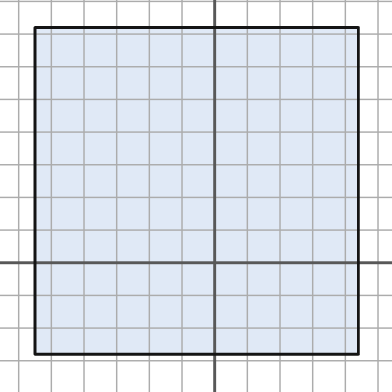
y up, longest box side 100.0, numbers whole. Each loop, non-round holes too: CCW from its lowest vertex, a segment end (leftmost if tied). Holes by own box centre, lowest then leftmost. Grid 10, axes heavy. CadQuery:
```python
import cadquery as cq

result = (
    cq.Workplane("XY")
    .moveTo(-55.0, -28.0)
    .lineTo(44.0, -28.0)
    .lineTo(44.0, 72.0)
    .lineTo(-55.0, 72.0)
    .close()
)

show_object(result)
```